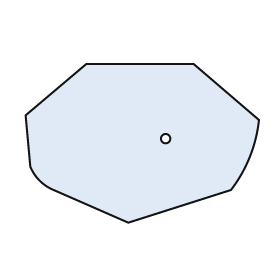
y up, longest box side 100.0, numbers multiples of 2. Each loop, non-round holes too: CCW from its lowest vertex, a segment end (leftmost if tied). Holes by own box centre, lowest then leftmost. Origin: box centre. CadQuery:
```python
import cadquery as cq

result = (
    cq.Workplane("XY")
    .moveTo(-6.0, -34.0)
    .lineTo(38.0, -20.0)
    .threePointArc((46.0, -6.0), (50.0, 10.0))
    .lineTo(22.0, 34.0)
    .lineTo(-24.0, 34.0)
    .lineTo(-50.0, 12.0)
    .lineTo(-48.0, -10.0)
    .threePointArc((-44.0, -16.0), (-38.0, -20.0))
    .close()
    .moveTo(10.0, 2.0)
    .circle(2.0)
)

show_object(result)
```